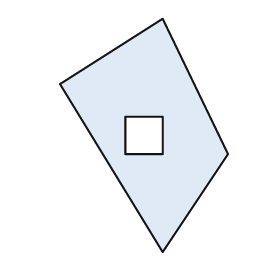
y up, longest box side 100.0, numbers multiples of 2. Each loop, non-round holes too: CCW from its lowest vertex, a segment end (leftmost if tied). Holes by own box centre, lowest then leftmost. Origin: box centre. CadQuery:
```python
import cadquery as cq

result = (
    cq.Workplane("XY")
    .moveTo(8.0, -50.0)
    .lineTo(36.0, -8.0)
    .lineTo(8.0, 50.0)
    .lineTo(-36.0, 22.0)
    .close()
    .moveTo(-8.0, -8.0)
    .lineTo(8.0, -8.0)
    .lineTo(8.0, 8.0)
    .lineTo(-8.0, 8.0)
    .close()
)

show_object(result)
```